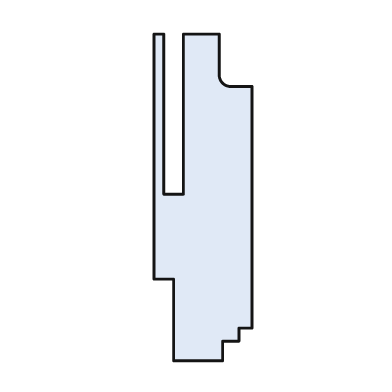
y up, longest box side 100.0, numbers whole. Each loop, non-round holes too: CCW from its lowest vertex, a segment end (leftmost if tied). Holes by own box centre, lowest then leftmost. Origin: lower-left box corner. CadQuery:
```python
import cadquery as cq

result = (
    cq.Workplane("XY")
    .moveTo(6.0, 0.0)
    .lineTo(21.0, 0.0)
    .lineTo(21.0, 6.0)
    .lineTo(26.0, 6.0)
    .lineTo(26.0, 10.0)
    .lineTo(30.0, 10.0)
    .lineTo(30.0, 84.0)
    .lineTo(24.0, 84.0)
    .threePointArc((21.0, 85.0), (20.0, 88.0))
    .lineTo(20.0, 100.0)
    .lineTo(9.0, 100.0)
    .lineTo(9.0, 51.0)
    .lineTo(3.0, 51.0)
    .lineTo(3.0, 100.0)
    .lineTo(0.0, 100.0)
    .lineTo(0.0, 25.0)
    .lineTo(6.0, 25.0)
    .close()
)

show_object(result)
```